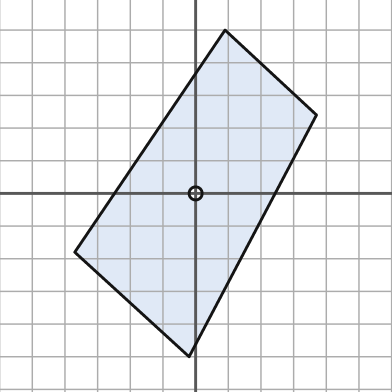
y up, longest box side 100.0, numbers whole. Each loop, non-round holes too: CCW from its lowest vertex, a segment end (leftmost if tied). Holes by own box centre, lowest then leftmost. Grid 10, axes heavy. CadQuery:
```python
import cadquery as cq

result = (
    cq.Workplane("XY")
    .moveTo(-2.0, -50.0)
    .lineTo(37.0, 24.0)
    .lineTo(9.0, 50.0)
    .lineTo(-37.0, -18.0)
    .close()
    .moveTo(0.0, 0.0)
    .circle(2.0)
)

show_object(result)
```